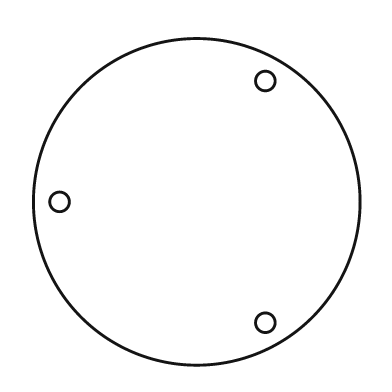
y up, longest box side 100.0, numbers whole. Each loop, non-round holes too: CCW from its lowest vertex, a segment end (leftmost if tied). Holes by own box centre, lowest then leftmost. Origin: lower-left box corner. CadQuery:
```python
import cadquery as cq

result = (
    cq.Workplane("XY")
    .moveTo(50.0, 50.0)
    .circle(50.0)
    .moveTo(71.0, 13.0)
    .circle(3.0)
    .moveTo(8.0, 50.0)
    .circle(3.0)
    .moveTo(71.0, 87.0)
    .circle(3.0)
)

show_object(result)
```